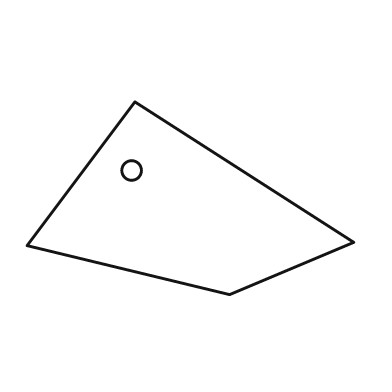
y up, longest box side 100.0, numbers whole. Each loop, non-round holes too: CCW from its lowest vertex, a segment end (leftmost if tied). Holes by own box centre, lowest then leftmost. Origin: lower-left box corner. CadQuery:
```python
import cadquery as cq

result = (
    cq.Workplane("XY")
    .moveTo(62.0, 0.0)
    .lineTo(100.0, 16.0)
    .lineTo(33.0, 59.0)
    .lineTo(0.0, 15.0)
    .close()
    .moveTo(32.0, 38.0)
    .circle(3.0)
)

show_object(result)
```